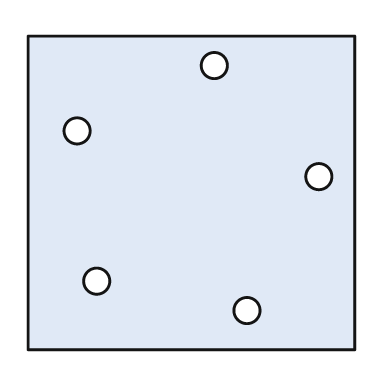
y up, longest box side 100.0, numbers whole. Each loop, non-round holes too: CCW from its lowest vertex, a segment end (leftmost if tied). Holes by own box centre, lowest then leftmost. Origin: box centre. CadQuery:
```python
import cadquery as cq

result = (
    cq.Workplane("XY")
    .moveTo(-50.0, -48.0)
    .lineTo(50.0, -48.0)
    .lineTo(50.0, 48.0)
    .lineTo(-50.0, 48.0)
    .close()
    .moveTo(17.0, -36.0)
    .circle(4.0)
    .moveTo(-29.0, -27.0)
    .circle(4.0)
    .moveTo(39.0, 5.0)
    .circle(4.0)
    .moveTo(-35.0, 19.0)
    .circle(4.0)
    .moveTo(7.0, 39.0)
    .circle(4.0)
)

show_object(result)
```